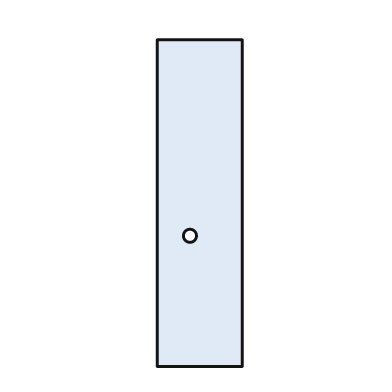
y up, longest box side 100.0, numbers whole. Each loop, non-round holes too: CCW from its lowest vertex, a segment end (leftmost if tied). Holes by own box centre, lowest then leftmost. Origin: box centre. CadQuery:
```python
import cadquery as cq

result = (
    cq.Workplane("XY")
    .moveTo(-13.0, -50.0)
    .lineTo(13.0, -50.0)
    .lineTo(13.0, 50.0)
    .lineTo(-13.0, 50.0)
    .close()
    .moveTo(-3.0, -10.0)
    .circle(2.0)
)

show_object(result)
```